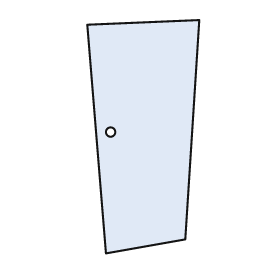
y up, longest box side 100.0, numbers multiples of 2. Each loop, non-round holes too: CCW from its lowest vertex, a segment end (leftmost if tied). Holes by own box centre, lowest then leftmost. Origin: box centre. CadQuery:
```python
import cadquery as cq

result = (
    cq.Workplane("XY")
    .moveTo(-16.0, -50.0)
    .lineTo(18.0, -44.0)
    .lineTo(24.0, 50.0)
    .lineTo(-24.0, 48.0)
    .close()
    .moveTo(-14.0, 2.0)
    .circle(2.0)
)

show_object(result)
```